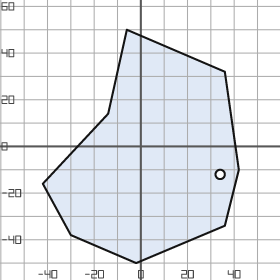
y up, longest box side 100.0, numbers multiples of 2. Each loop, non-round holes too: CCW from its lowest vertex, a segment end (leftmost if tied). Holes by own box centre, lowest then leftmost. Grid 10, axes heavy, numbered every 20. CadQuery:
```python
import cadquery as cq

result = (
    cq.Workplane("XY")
    .moveTo(-2.0, -50.0)
    .lineTo(36.0, -34.0)
    .lineTo(42.0, -10.0)
    .lineTo(36.0, 32.0)
    .lineTo(-6.0, 50.0)
    .lineTo(-14.0, 14.0)
    .lineTo(-42.0, -16.0)
    .lineTo(-30.0, -38.0)
    .close()
    .moveTo(34.0, -12.0)
    .circle(2.0)
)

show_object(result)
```